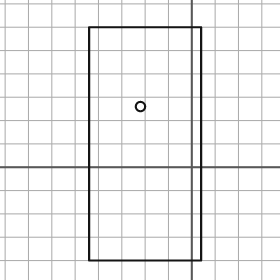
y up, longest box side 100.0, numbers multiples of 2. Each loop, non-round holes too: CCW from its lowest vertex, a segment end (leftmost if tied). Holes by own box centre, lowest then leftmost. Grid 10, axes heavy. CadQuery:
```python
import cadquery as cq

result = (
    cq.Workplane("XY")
    .moveTo(-44.0, -40.0)
    .lineTo(4.0, -40.0)
    .lineTo(4.0, 60.0)
    .lineTo(-44.0, 60.0)
    .close()
    .moveTo(-22.0, 26.0)
    .circle(2.0)
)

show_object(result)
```